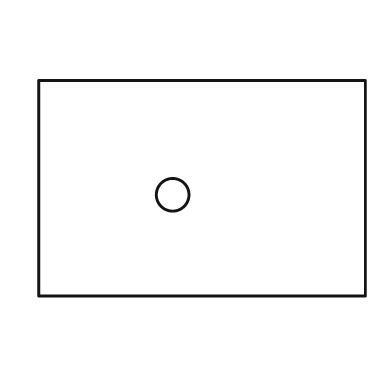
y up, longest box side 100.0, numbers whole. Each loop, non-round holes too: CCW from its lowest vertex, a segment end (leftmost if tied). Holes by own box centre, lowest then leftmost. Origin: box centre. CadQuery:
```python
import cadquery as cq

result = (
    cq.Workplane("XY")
    .moveTo(-50.0, -33.0)
    .lineTo(50.0, -33.0)
    .lineTo(50.0, 33.0)
    .lineTo(-50.0, 33.0)
    .close()
    .moveTo(-9.0, -2.0)
    .circle(5.0)
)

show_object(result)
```